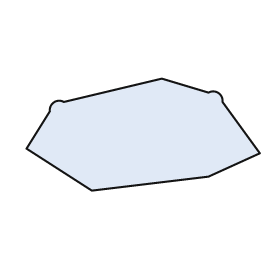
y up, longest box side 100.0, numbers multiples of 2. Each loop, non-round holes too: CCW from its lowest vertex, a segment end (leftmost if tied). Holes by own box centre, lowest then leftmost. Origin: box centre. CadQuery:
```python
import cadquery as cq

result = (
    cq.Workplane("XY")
    .moveTo(-22.0, -24.0)
    .lineTo(28.0, -18.0)
    .lineTo(50.0, -8.0)
    .lineTo(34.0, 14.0)
    .threePointArc((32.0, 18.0), (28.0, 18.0))
    .lineTo(8.0, 24.0)
    .lineTo(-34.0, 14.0)
    .threePointArc((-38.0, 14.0), (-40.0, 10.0))
    .lineTo(-50.0, -6.0)
    .close()
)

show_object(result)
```